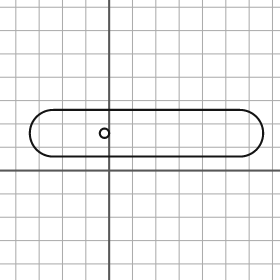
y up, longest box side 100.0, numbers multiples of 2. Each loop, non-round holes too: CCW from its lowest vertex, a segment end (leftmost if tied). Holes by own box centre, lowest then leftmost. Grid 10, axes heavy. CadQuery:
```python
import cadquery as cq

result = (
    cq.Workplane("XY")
    .moveTo(-24.0, 6.0)
    .lineTo(56.0, 6.0)
    .threePointArc((66.0, 16.0), (56.0, 26.0))
    .lineTo(-24.0, 26.0)
    .threePointArc((-34.0, 16.0), (-24.0, 6.0))
    .close()
    .moveTo(-2.0, 16.0)
    .circle(2.0)
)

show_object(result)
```